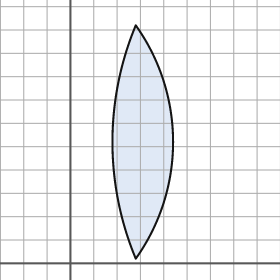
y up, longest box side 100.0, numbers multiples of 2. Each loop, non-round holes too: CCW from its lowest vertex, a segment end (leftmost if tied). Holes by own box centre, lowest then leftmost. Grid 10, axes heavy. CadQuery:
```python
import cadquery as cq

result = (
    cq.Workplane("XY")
    .moveTo(28.0, 2.0)
    .threePointArc((44.0, 52.0), (28.0, 102.0))
    .threePointArc((18.0, 52.0), (28.0, 2.0))
    .close()
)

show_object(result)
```